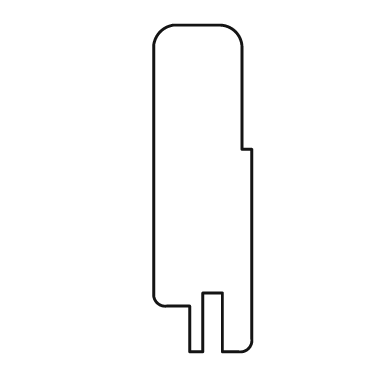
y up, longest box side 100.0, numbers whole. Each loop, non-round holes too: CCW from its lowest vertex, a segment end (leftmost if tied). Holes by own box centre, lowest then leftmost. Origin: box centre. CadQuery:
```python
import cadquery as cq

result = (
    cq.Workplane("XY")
    .moveTo(-4.0, -50.0)
    .lineTo(0.0, -50.0)
    .lineTo(0.0, -32.0)
    .lineTo(6.0, -32.0)
    .lineTo(6.0, -50.0)
    .lineTo(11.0, -50.0)
    .threePointArc((14.0, -49.0), (15.0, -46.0))
    .lineTo(15.0, 12.0)
    .lineTo(12.0, 12.0)
    .lineTo(12.0, 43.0)
    .threePointArc((10.0, 48.0), (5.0, 50.0))
    .lineTo(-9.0, 50.0)
    .threePointArc((-13.0, 48.0), (-15.0, 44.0))
    .lineTo(-15.0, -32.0)
    .threePointArc((-14.0, -35.0), (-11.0, -36.0))
    .lineTo(-4.0, -36.0)
    .close()
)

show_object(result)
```